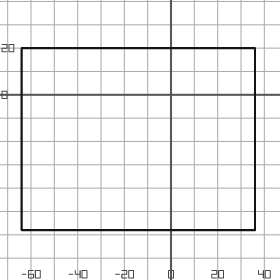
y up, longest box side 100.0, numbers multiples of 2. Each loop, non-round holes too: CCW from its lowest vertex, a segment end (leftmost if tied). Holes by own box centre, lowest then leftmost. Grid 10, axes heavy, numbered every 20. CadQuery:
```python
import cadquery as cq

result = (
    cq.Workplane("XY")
    .moveTo(-64.0, -58.0)
    .lineTo(36.0, -58.0)
    .lineTo(36.0, 20.0)
    .lineTo(-64.0, 20.0)
    .close()
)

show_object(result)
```